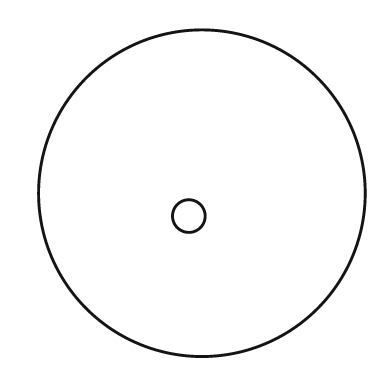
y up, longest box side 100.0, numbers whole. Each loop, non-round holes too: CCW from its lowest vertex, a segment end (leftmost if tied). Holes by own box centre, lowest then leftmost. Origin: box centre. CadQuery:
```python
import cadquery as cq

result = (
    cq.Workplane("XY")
    .moveTo(0.0, 0.0)
    .circle(50.0)
    .moveTo(-4.0, -7.0)
    .circle(5.0)
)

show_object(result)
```